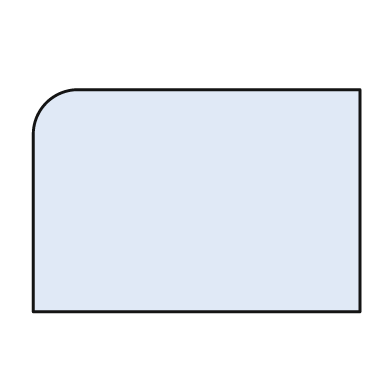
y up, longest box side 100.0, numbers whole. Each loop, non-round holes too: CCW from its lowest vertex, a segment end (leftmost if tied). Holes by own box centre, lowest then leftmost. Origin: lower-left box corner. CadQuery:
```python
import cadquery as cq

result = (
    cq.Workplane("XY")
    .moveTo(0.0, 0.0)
    .lineTo(100.0, 0.0)
    .lineTo(100.0, 68.0)
    .lineTo(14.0, 68.0)
    .threePointArc((4.0, 64.0), (0.0, 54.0))
    .close()
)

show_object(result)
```